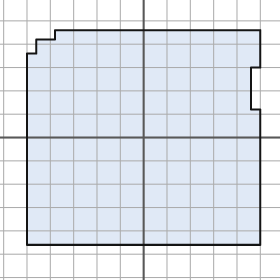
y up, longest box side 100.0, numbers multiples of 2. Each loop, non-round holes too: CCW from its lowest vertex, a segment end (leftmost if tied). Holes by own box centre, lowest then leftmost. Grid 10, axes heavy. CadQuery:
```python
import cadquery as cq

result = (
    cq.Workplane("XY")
    .moveTo(-50.0, -46.0)
    .lineTo(50.0, -46.0)
    .lineTo(50.0, 12.0)
    .lineTo(46.0, 12.0)
    .lineTo(46.0, 30.0)
    .lineTo(50.0, 30.0)
    .lineTo(50.0, 46.0)
    .lineTo(-38.0, 46.0)
    .lineTo(-38.0, 42.0)
    .lineTo(-46.0, 42.0)
    .lineTo(-46.0, 36.0)
    .lineTo(-50.0, 36.0)
    .close()
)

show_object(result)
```